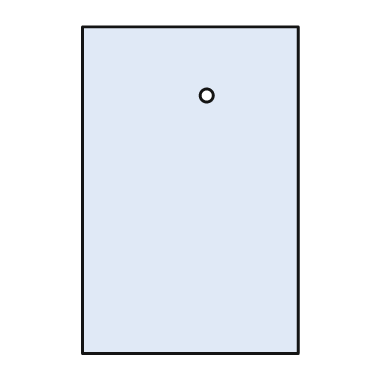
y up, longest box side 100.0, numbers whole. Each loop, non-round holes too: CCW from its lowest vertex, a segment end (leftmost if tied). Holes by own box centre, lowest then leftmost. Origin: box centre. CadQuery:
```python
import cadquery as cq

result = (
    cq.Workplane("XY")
    .moveTo(-33.0, -50.0)
    .lineTo(33.0, -50.0)
    .lineTo(33.0, 50.0)
    .lineTo(-33.0, 50.0)
    .close()
    .moveTo(5.0, 29.0)
    .circle(2.0)
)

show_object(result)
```